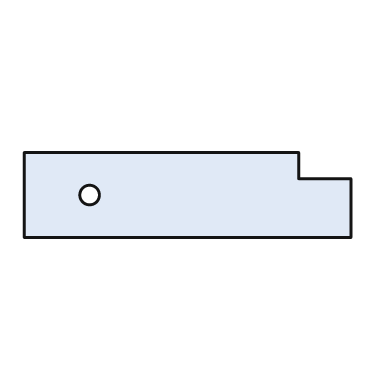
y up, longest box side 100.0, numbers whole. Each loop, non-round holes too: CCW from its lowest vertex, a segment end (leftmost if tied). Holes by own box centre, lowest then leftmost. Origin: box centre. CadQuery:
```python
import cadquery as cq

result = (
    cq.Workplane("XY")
    .moveTo(-50.0, -13.0)
    .lineTo(50.0, -13.0)
    .lineTo(50.0, 5.0)
    .lineTo(34.0, 5.0)
    .lineTo(34.0, 13.0)
    .lineTo(-50.0, 13.0)
    .close()
    .moveTo(-30.0, 0.0)
    .circle(3.0)
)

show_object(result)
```